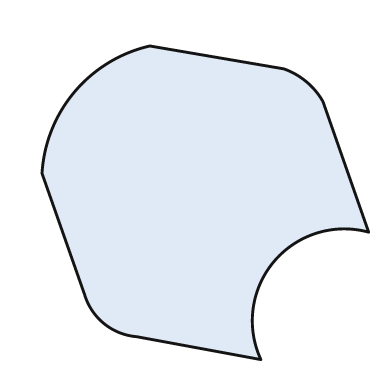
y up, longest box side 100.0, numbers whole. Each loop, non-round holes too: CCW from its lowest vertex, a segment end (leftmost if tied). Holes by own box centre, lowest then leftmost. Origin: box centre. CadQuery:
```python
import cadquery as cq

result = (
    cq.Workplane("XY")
    .moveTo(17.0, -48.0)
    .threePointArc((21.0, -18.0), (50.0, -9.0))
    .lineTo(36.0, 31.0)
    .threePointArc((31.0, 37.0), (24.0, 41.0))
    .lineTo(-17.0, 48.0)
    .threePointArc((-40.0, 34.0), (-50.0, 9.0))
    .lineTo(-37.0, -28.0)
    .threePointArc((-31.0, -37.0), (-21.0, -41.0))
    .close()
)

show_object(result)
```